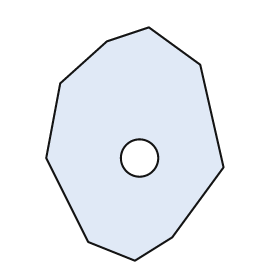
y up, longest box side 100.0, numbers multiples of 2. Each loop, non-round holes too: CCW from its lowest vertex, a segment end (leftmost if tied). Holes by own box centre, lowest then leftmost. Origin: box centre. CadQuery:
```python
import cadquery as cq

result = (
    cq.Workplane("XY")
    .moveTo(0.0, -50.0)
    .lineTo(16.0, -40.0)
    .lineTo(38.0, -10.0)
    .lineTo(28.0, 34.0)
    .lineTo(6.0, 50.0)
    .lineTo(-12.0, 44.0)
    .lineTo(-32.0, 26.0)
    .lineTo(-38.0, -6.0)
    .lineTo(-20.0, -42.0)
    .close()
    .moveTo(2.0, -6.0)
    .circle(8.0)
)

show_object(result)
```